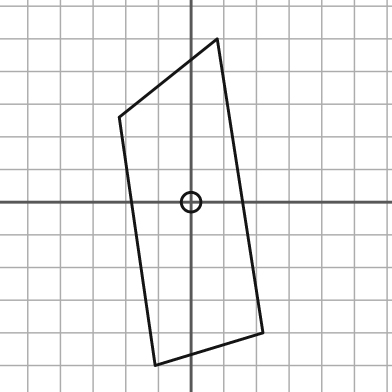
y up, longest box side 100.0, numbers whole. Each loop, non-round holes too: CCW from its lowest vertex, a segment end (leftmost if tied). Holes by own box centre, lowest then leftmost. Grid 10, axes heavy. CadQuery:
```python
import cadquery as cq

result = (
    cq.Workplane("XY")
    .moveTo(-11.0, -50.0)
    .lineTo(22.0, -40.0)
    .lineTo(8.0, 50.0)
    .lineTo(-22.0, 26.0)
    .close()
    .moveTo(0.0, 0.0)
    .circle(3.0)
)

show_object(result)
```